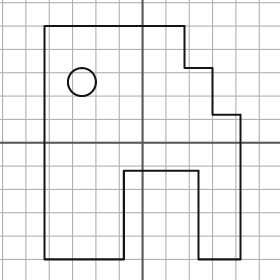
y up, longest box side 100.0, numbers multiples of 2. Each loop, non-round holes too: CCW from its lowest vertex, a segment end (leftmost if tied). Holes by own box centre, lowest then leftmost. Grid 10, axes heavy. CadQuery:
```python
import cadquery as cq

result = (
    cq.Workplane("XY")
    .moveTo(-42.0, -50.0)
    .lineTo(-8.0, -50.0)
    .lineTo(-8.0, -12.0)
    .lineTo(24.0, -12.0)
    .lineTo(24.0, -50.0)
    .lineTo(42.0, -50.0)
    .lineTo(42.0, 12.0)
    .lineTo(30.0, 12.0)
    .lineTo(30.0, 32.0)
    .lineTo(18.0, 32.0)
    .lineTo(18.0, 50.0)
    .lineTo(-42.0, 50.0)
    .close()
    .moveTo(-26.0, 26.0)
    .circle(6.0)
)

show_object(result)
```